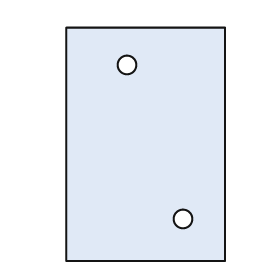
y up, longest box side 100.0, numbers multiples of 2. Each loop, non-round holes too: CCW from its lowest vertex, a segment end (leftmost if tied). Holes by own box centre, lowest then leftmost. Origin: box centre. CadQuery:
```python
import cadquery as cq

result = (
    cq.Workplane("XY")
    .moveTo(-34.0, -50.0)
    .lineTo(34.0, -50.0)
    .lineTo(34.0, 50.0)
    .lineTo(-34.0, 50.0)
    .close()
    .moveTo(16.0, -32.0)
    .circle(4.0)
    .moveTo(-8.0, 34.0)
    .circle(4.0)
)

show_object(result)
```